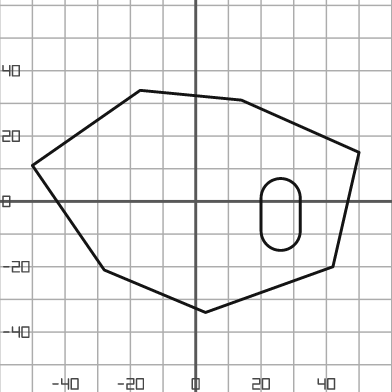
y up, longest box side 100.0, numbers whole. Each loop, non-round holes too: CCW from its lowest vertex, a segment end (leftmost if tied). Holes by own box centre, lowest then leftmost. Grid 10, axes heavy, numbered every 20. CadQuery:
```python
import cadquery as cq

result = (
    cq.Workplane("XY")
    .moveTo(3.0, -34.0)
    .lineTo(42.0, -20.0)
    .lineTo(50.0, 15.0)
    .lineTo(14.0, 31.0)
    .lineTo(-17.0, 34.0)
    .lineTo(-50.0, 11.0)
    .lineTo(-28.0, -21.0)
    .close()
    .moveTo(20.0, -9.0)
    .threePointArc((26.0, -15.0), (32.0, -9.0))
    .lineTo(32.0, 1.0)
    .threePointArc((26.0, 7.0), (20.0, 1.0))
    .close()
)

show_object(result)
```